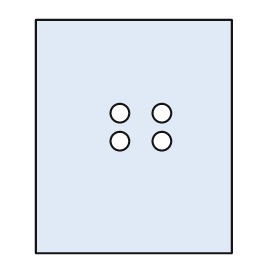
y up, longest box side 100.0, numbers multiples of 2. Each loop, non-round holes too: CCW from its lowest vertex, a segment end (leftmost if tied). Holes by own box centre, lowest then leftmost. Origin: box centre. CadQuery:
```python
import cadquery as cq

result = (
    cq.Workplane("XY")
    .moveTo(-42.0, -50.0)
    .lineTo(42.0, -50.0)
    .lineTo(42.0, 50.0)
    .lineTo(-42.0, 50.0)
    .close()
    .moveTo(-6.0, -2.0)
    .circle(4.0)
    .moveTo(12.0, -2.0)
    .circle(4.0)
    .moveTo(-6.0, 10.0)
    .circle(4.0)
    .moveTo(12.0, 10.0)
    .circle(4.0)
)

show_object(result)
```